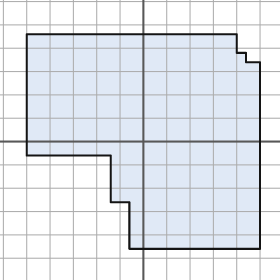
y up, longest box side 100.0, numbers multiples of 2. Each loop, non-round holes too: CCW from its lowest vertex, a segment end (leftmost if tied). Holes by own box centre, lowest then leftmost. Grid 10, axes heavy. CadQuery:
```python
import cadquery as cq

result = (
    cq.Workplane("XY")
    .moveTo(-6.0, -46.0)
    .lineTo(50.0, -46.0)
    .lineTo(50.0, 34.0)
    .lineTo(44.0, 34.0)
    .lineTo(44.0, 38.0)
    .lineTo(40.0, 38.0)
    .lineTo(40.0, 46.0)
    .lineTo(-50.0, 46.0)
    .lineTo(-50.0, -6.0)
    .lineTo(-14.0, -6.0)
    .lineTo(-14.0, -26.0)
    .lineTo(-6.0, -26.0)
    .close()
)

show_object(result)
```